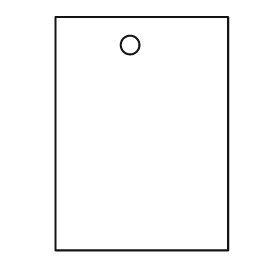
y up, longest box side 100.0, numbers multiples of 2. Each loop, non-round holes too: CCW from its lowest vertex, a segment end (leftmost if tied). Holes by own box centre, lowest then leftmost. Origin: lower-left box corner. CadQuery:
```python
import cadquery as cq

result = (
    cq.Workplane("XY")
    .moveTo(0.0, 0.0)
    .lineTo(74.0, 0.0)
    .lineTo(74.0, 100.0)
    .lineTo(0.0, 100.0)
    .close()
    .moveTo(32.0, 88.0)
    .circle(4.0)
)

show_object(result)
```